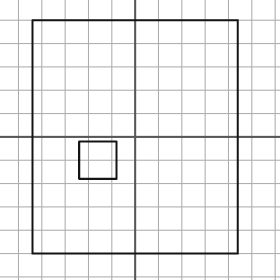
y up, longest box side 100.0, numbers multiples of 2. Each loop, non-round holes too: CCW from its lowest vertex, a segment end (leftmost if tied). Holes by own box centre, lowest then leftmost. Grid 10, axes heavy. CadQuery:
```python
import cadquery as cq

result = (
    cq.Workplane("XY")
    .moveTo(-44.0, -50.0)
    .lineTo(44.0, -50.0)
    .lineTo(44.0, 50.0)
    .lineTo(-44.0, 50.0)
    .close()
    .moveTo(-24.0, -18.0)
    .lineTo(-8.0, -18.0)
    .lineTo(-8.0, -2.0)
    .lineTo(-24.0, -2.0)
    .close()
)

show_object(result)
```